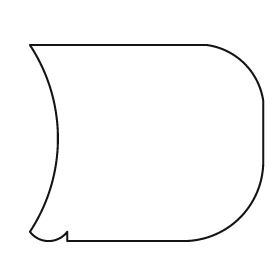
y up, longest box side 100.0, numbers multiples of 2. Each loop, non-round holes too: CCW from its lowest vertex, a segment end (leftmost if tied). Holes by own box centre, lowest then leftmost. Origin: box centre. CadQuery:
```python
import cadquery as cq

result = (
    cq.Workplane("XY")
    .moveTo(-34.0, -42.0)
    .lineTo(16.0, -42.0)
    .threePointArc((40.0, -32.0), (50.0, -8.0))
    .lineTo(50.0, 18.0)
    .threePointArc((42.0, 34.0), (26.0, 42.0))
    .lineTo(-50.0, 42.0)
    .threePointArc((-38.0, 2.0), (-50.0, -38.0))
    .threePointArc((-42.0, -42.0), (-34.0, -38.0))
    .close()
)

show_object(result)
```